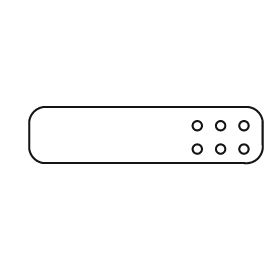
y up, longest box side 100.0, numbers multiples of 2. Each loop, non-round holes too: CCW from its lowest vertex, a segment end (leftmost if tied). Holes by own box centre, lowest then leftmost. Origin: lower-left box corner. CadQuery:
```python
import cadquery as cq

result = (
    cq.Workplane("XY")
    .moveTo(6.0, 0.0)
    .lineTo(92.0, 0.0)
    .threePointArc((98.0, 2.0), (100.0, 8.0))
    .lineTo(100.0, 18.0)
    .threePointArc((98.0, 22.0), (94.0, 24.0))
    .lineTo(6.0, 24.0)
    .threePointArc((2.0, 22.0), (0.0, 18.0))
    .lineTo(0.0, 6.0)
    .threePointArc((2.0, 2.0), (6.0, 0.0))
    .close()
    .moveTo(72.0, 6.0)
    .circle(2.0)
    .moveTo(82.0, 6.0)
    .circle(2.0)
    .moveTo(92.0, 6.0)
    .circle(2.0)
    .moveTo(72.0, 16.0)
    .circle(2.0)
    .moveTo(82.0, 16.0)
    .circle(2.0)
    .moveTo(92.0, 16.0)
    .circle(2.0)
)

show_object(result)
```